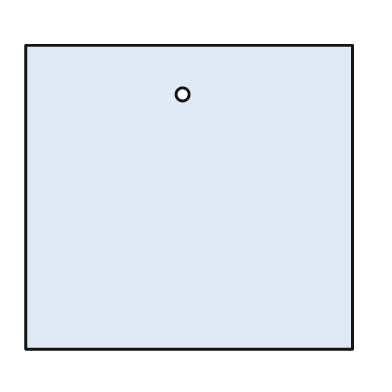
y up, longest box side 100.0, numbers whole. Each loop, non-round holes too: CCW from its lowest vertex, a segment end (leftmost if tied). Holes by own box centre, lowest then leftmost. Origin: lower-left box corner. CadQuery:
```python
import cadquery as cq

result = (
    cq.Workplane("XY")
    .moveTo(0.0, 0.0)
    .lineTo(100.0, 0.0)
    .lineTo(100.0, 93.0)
    .lineTo(0.0, 93.0)
    .close()
    .moveTo(48.0, 78.0)
    .circle(2.0)
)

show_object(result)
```